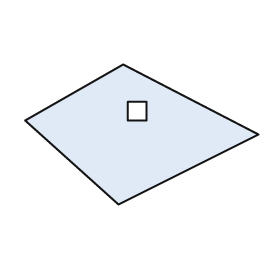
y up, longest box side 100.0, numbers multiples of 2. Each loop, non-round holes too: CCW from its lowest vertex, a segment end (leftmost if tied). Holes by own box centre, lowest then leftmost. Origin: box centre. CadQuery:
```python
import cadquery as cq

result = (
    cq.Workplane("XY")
    .moveTo(-10.0, -30.0)
    .lineTo(50.0, 0.0)
    .lineTo(-8.0, 30.0)
    .lineTo(-50.0, 6.0)
    .close()
    .moveTo(-6.0, 6.0)
    .lineTo(2.0, 6.0)
    .lineTo(2.0, 14.0)
    .lineTo(-6.0, 14.0)
    .close()
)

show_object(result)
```